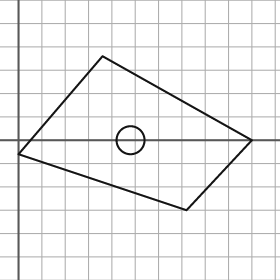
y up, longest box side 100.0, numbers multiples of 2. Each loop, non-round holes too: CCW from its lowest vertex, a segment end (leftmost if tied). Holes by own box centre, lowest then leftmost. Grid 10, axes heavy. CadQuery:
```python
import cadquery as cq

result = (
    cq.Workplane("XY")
    .moveTo(72.0, -30.0)
    .lineTo(100.0, 0.0)
    .lineTo(36.0, 36.0)
    .lineTo(0.0, -6.0)
    .close()
    .moveTo(48.0, 0.0)
    .circle(6.0)
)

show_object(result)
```